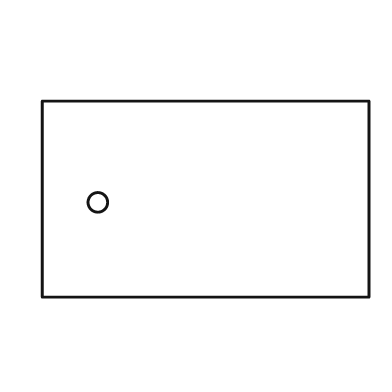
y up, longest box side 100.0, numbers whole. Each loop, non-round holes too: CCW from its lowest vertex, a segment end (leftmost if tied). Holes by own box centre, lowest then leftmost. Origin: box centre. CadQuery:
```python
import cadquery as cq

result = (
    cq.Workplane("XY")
    .moveTo(-50.0, -30.0)
    .lineTo(50.0, -30.0)
    .lineTo(50.0, 30.0)
    .lineTo(-50.0, 30.0)
    .close()
    .moveTo(-33.0, -1.0)
    .circle(3.0)
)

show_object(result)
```